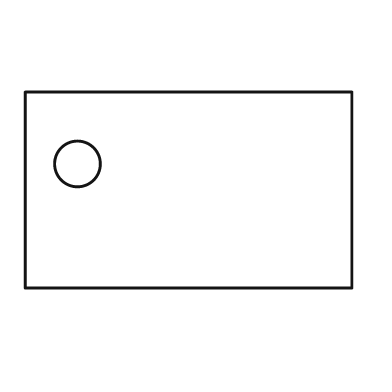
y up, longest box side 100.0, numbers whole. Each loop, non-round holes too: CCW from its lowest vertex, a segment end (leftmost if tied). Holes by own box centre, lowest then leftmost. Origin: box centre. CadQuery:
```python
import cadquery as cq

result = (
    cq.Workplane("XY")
    .moveTo(-50.0, -30.0)
    .lineTo(50.0, -30.0)
    .lineTo(50.0, 30.0)
    .lineTo(-50.0, 30.0)
    .close()
    .moveTo(-34.0, 8.0)
    .circle(7.0)
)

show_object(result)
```